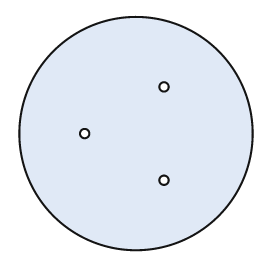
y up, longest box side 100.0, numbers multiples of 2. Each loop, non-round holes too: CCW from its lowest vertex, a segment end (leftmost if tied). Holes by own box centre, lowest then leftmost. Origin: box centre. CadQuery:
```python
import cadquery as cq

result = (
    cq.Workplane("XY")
    .moveTo(0.0, 0.0)
    .circle(50.0)
    .moveTo(12.0, -20.0)
    .circle(2.0)
    .moveTo(-22.0, 0.0)
    .circle(2.0)
    .moveTo(12.0, 20.0)
    .circle(2.0)
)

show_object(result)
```